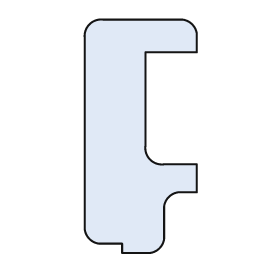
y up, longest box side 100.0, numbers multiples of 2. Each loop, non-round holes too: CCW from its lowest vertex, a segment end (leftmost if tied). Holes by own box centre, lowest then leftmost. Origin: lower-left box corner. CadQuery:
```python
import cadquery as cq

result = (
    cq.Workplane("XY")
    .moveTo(16.0, 0.0)
    .lineTo(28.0, 0.0)
    .threePointArc((32.0, 2.0), (34.0, 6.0))
    .lineTo(34.0, 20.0)
    .threePointArc((36.0, 24.0), (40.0, 26.0))
    .lineTo(48.0, 26.0)
    .lineTo(48.0, 38.0)
    .lineTo(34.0, 38.0)
    .threePointArc((28.0, 40.0), (26.0, 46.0))
    .lineTo(26.0, 86.0)
    .lineTo(48.0, 86.0)
    .lineTo(48.0, 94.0)
    .threePointArc((46.0, 98.0), (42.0, 100.0))
    .lineTo(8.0, 100.0)
    .threePointArc((2.0, 98.0), (0.0, 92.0))
    .lineTo(0.0, 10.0)
    .threePointArc((2.0, 6.0), (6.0, 4.0))
    .lineTo(16.0, 4.0)
    .close()
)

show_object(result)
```